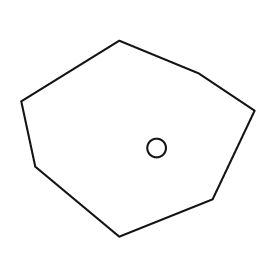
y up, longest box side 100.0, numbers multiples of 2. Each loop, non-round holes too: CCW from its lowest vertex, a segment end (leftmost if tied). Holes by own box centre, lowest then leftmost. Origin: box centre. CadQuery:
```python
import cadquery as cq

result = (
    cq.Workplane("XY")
    .moveTo(-8.0, -42.0)
    .lineTo(32.0, -26.0)
    .lineTo(50.0, 12.0)
    .lineTo(26.0, 28.0)
    .lineTo(-8.0, 42.0)
    .lineTo(-50.0, 16.0)
    .lineTo(-44.0, -12.0)
    .close()
    .moveTo(8.0, -4.0)
    .circle(4.0)
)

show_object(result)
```